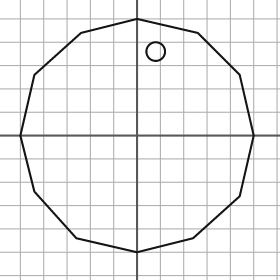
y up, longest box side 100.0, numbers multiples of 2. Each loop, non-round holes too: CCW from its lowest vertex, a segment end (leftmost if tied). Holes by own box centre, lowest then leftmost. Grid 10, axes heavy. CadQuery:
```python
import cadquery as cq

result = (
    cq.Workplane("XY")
    .moveTo(0.0, -50.0)
    .lineTo(24.0, -44.0)
    .lineTo(44.0, -26.0)
    .lineTo(50.0, 0.0)
    .lineTo(44.0, 26.0)
    .lineTo(26.0, 44.0)
    .lineTo(0.0, 50.0)
    .lineTo(-24.0, 44.0)
    .lineTo(-44.0, 26.0)
    .lineTo(-50.0, 0.0)
    .lineTo(-44.0, -24.0)
    .lineTo(-26.0, -44.0)
    .close()
    .moveTo(8.0, 36.0)
    .circle(4.0)
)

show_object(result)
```